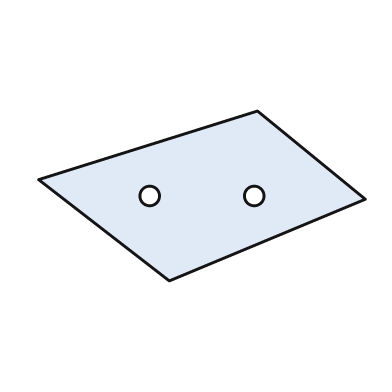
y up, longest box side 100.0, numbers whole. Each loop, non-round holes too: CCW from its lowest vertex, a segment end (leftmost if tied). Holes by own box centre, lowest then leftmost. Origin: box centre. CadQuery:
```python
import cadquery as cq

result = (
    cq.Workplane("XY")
    .moveTo(-10.0, -26.0)
    .lineTo(50.0, -1.0)
    .lineTo(17.0, 26.0)
    .lineTo(-50.0, 5.0)
    .close()
    .moveTo(-16.0, 0.0)
    .circle(3.0)
    .moveTo(16.0, 0.0)
    .circle(3.0)
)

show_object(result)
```